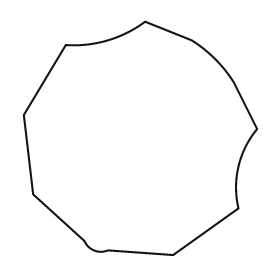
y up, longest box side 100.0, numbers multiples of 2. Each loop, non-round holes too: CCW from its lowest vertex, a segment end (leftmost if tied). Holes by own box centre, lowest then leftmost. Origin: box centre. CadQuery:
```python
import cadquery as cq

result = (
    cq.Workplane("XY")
    .moveTo(14.0, -50.0)
    .lineTo(42.0, -30.0)
    .threePointArc((42.0, -12.0), (50.0, 4.0))
    .lineTo(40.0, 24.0)
    .threePointArc((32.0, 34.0), (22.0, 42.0))
    .lineTo(2.0, 50.0)
    .threePointArc((-14.0, 42.0), (-32.0, 40.0))
    .lineTo(-50.0, 10.0)
    .lineTo(-46.0, -24.0)
    .lineTo(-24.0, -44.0)
    .threePointArc((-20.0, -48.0), (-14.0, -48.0))
    .close()
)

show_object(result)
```